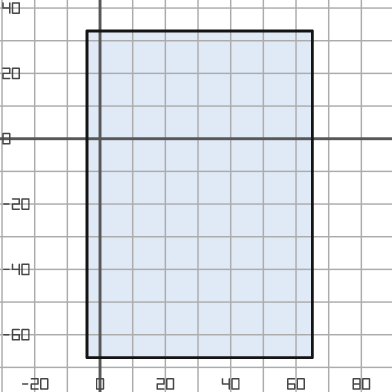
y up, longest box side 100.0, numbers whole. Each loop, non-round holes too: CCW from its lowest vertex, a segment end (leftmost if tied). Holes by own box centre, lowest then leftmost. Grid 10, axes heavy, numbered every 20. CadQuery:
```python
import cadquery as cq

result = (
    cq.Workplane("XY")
    .moveTo(-4.0, -67.0)
    .lineTo(65.0, -67.0)
    .lineTo(65.0, 33.0)
    .lineTo(-4.0, 33.0)
    .close()
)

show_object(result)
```